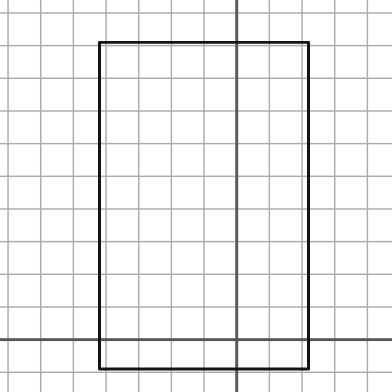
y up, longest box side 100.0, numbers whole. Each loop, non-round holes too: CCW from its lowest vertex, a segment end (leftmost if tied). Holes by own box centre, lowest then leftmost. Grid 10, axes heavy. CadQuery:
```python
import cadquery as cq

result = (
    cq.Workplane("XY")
    .moveTo(-42.0, -9.0)
    .lineTo(22.0, -9.0)
    .lineTo(22.0, 91.0)
    .lineTo(-42.0, 91.0)
    .close()
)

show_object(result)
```